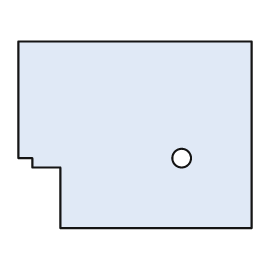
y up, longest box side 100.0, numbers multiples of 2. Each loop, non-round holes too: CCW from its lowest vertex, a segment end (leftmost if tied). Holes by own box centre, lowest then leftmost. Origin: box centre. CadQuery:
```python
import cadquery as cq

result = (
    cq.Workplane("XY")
    .moveTo(-32.0, -40.0)
    .lineTo(50.0, -40.0)
    .lineTo(50.0, 40.0)
    .lineTo(-50.0, 40.0)
    .lineTo(-50.0, -10.0)
    .lineTo(-44.0, -10.0)
    .lineTo(-44.0, -14.0)
    .lineTo(-32.0, -14.0)
    .close()
    .moveTo(20.0, -10.0)
    .circle(4.0)
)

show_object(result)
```